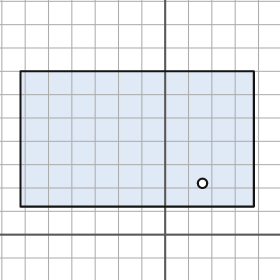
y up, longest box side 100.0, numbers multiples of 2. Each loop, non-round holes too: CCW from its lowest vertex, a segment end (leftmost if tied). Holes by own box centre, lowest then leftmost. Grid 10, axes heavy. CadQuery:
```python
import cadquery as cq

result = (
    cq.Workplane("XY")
    .moveTo(-62.0, 12.0)
    .lineTo(38.0, 12.0)
    .lineTo(38.0, 70.0)
    .lineTo(-62.0, 70.0)
    .close()
    .moveTo(16.0, 22.0)
    .circle(2.0)
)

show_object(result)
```